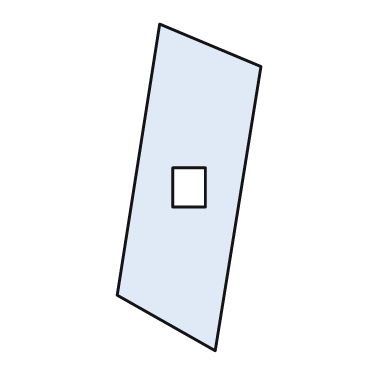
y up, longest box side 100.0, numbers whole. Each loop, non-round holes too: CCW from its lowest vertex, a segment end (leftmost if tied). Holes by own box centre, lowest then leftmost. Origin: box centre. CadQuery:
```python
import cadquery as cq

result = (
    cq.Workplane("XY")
    .moveTo(8.0, -50.0)
    .lineTo(22.0, 37.0)
    .lineTo(-9.0, 50.0)
    .lineTo(-22.0, -33.0)
    .close()
    .moveTo(-5.0, -6.0)
    .lineTo(5.0, -6.0)
    .lineTo(5.0, 6.0)
    .lineTo(-5.0, 6.0)
    .close()
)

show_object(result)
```